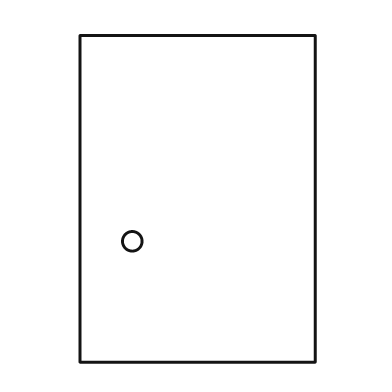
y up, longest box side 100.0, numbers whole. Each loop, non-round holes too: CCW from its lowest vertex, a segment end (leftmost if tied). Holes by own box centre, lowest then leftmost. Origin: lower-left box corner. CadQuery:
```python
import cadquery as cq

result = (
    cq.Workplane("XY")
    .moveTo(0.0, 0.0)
    .lineTo(72.0, 0.0)
    .lineTo(72.0, 100.0)
    .lineTo(0.0, 100.0)
    .close()
    .moveTo(16.0, 37.0)
    .circle(3.0)
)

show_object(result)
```